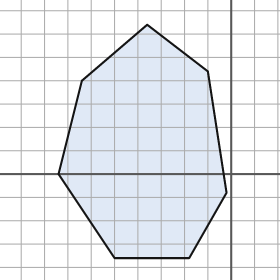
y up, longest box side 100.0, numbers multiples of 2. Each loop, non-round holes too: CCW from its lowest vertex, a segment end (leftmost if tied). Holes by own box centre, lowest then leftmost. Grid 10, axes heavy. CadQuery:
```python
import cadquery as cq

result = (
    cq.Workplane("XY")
    .moveTo(-50.0, -36.0)
    .lineTo(-18.0, -36.0)
    .lineTo(-2.0, -8.0)
    .lineTo(-10.0, 44.0)
    .lineTo(-36.0, 64.0)
    .lineTo(-64.0, 40.0)
    .lineTo(-74.0, 0.0)
    .close()
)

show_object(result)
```